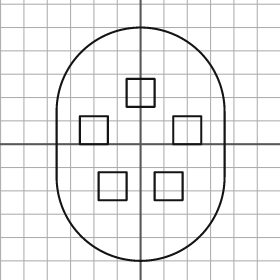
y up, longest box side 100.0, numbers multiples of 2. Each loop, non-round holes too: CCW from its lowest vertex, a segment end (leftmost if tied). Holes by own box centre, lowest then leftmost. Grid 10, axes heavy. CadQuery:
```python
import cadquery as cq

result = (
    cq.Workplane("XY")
    .moveTo(-36.0, -14.0)
    .threePointArc((0.0, -50.0), (36.0, -14.0))
    .lineTo(36.0, 14.0)
    .threePointArc((0.0, 50.0), (-36.0, 14.0))
    .close()
    .moveTo(-18.0, -24.0)
    .lineTo(-6.0, -24.0)
    .lineTo(-6.0, -12.0)
    .lineTo(-18.0, -12.0)
    .close()
    .moveTo(6.0, -24.0)
    .lineTo(18.0, -24.0)
    .lineTo(18.0, -12.0)
    .lineTo(6.0, -12.0)
    .close()
    .moveTo(-26.0, 0.0)
    .lineTo(-14.0, 0.0)
    .lineTo(-14.0, 12.0)
    .lineTo(-26.0, 12.0)
    .close()
    .moveTo(14.0, 0.0)
    .lineTo(26.0, 0.0)
    .lineTo(26.0, 12.0)
    .lineTo(14.0, 12.0)
    .close()
    .moveTo(-6.0, 16.0)
    .lineTo(6.0, 16.0)
    .lineTo(6.0, 28.0)
    .lineTo(-6.0, 28.0)
    .close()
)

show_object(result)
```